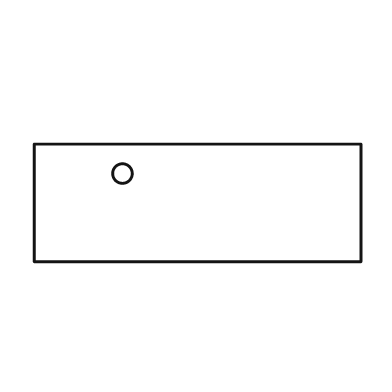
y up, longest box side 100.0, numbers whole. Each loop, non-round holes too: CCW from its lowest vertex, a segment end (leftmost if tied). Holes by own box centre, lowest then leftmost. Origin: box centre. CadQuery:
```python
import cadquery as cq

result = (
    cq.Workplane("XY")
    .moveTo(-50.0, -18.0)
    .lineTo(50.0, -18.0)
    .lineTo(50.0, 18.0)
    .lineTo(-50.0, 18.0)
    .close()
    .moveTo(-23.0, 9.0)
    .circle(3.0)
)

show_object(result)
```